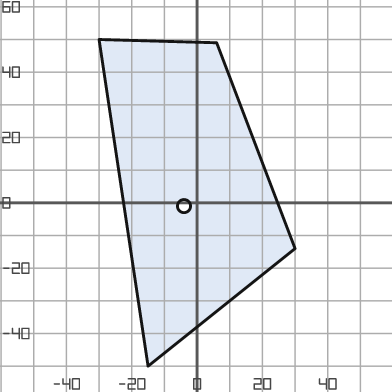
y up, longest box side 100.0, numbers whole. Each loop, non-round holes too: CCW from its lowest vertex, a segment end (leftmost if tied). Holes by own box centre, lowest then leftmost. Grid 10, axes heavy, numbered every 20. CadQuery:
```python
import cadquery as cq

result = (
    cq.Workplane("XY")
    .moveTo(-15.0, -50.0)
    .lineTo(30.0, -14.0)
    .lineTo(6.0, 49.0)
    .lineTo(-30.0, 50.0)
    .close()
    .moveTo(-4.0, -1.0)
    .circle(2.0)
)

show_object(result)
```